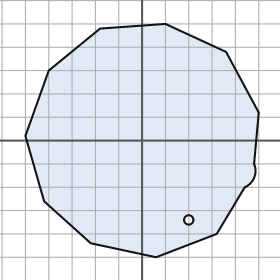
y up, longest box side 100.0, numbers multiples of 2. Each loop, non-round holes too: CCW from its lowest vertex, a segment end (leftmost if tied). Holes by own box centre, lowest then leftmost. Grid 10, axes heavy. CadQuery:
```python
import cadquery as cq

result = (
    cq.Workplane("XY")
    .moveTo(6.0, -50.0)
    .lineTo(32.0, -40.0)
    .lineTo(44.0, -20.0)
    .threePointArc((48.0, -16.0), (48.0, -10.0))
    .lineTo(50.0, 12.0)
    .lineTo(36.0, 38.0)
    .lineTo(10.0, 50.0)
    .lineTo(-18.0, 48.0)
    .lineTo(-40.0, 30.0)
    .lineTo(-50.0, 2.0)
    .lineTo(-42.0, -26.0)
    .lineTo(-22.0, -44.0)
    .close()
    .moveTo(20.0, -34.0)
    .circle(2.0)
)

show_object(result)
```